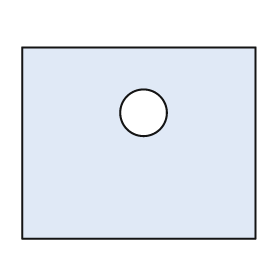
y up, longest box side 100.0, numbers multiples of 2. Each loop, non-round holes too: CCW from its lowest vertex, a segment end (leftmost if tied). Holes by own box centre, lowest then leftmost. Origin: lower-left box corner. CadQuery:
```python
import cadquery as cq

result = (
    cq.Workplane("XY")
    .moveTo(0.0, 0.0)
    .lineTo(100.0, 0.0)
    .lineTo(100.0, 82.0)
    .lineTo(0.0, 82.0)
    .close()
    .moveTo(52.0, 54.0)
    .circle(10.0)
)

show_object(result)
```